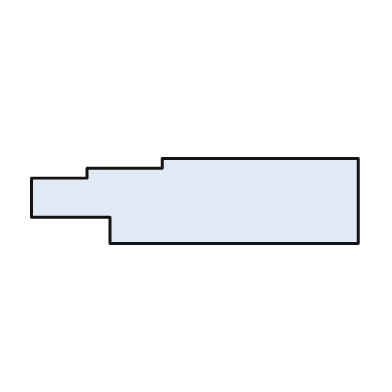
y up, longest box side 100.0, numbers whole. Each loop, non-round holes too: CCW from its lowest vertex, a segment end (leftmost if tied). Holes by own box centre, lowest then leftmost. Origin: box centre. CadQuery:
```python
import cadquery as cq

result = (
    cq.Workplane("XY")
    .moveTo(-26.0, -13.0)
    .lineTo(50.0, -13.0)
    .lineTo(50.0, 13.0)
    .lineTo(-10.0, 13.0)
    .lineTo(-10.0, 10.0)
    .lineTo(-33.0, 10.0)
    .lineTo(-33.0, 7.0)
    .lineTo(-50.0, 7.0)
    .lineTo(-50.0, -5.0)
    .lineTo(-26.0, -5.0)
    .close()
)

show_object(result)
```